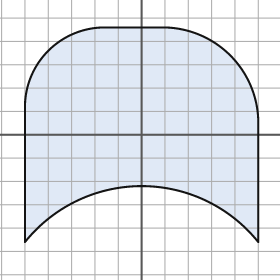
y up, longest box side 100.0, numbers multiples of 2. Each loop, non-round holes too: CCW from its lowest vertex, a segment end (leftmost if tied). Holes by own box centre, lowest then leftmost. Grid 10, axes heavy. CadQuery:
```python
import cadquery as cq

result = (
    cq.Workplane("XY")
    .moveTo(-50.0, -46.0)
    .threePointArc((0.0, -22.0), (50.0, -46.0))
    .lineTo(50.0, 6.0)
    .threePointArc((38.0, 34.0), (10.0, 46.0))
    .lineTo(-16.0, 46.0)
    .threePointArc((-40.0, 36.0), (-50.0, 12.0))
    .close()
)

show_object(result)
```